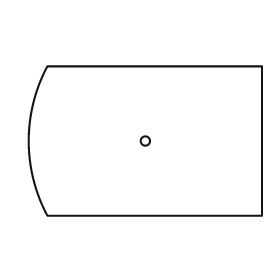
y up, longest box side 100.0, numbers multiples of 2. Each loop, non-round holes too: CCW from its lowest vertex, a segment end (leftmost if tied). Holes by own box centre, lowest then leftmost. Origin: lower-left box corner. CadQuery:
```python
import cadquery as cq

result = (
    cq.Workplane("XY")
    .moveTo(8.0, 0.0)
    .lineTo(100.0, 0.0)
    .lineTo(100.0, 64.0)
    .lineTo(8.0, 64.0)
    .threePointArc((0.0, 32.0), (8.0, 0.0))
    .close()
    .moveTo(50.0, 32.0)
    .circle(2.0)
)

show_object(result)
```